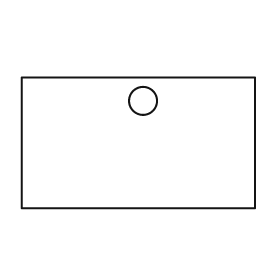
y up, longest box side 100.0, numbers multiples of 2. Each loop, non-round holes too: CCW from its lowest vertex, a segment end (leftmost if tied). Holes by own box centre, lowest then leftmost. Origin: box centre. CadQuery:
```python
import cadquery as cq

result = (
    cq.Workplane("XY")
    .moveTo(-50.0, -28.0)
    .lineTo(50.0, -28.0)
    .lineTo(50.0, 28.0)
    .lineTo(-50.0, 28.0)
    .close()
    .moveTo(2.0, 18.0)
    .circle(6.0)
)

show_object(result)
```